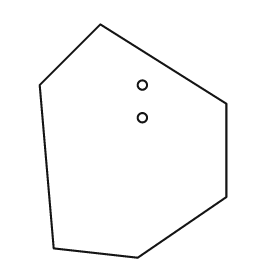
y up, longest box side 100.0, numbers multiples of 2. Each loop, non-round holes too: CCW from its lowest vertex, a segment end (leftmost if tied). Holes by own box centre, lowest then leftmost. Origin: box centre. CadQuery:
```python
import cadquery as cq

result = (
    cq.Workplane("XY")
    .moveTo(2.0, -50.0)
    .lineTo(40.0, -24.0)
    .lineTo(40.0, 16.0)
    .lineTo(-14.0, 50.0)
    .lineTo(-40.0, 24.0)
    .lineTo(-34.0, -46.0)
    .close()
    .moveTo(4.0, 10.0)
    .circle(2.0)
    .moveTo(4.0, 24.0)
    .circle(2.0)
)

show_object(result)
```